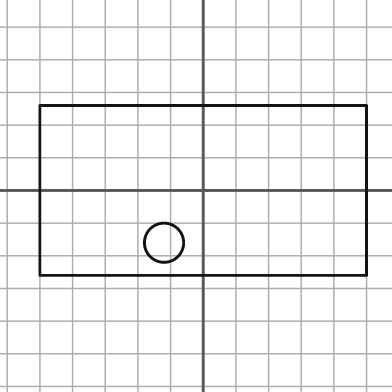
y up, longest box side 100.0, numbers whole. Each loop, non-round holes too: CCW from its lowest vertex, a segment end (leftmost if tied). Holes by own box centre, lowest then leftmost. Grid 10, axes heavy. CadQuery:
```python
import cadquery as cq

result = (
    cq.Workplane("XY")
    .moveTo(-50.0, -26.0)
    .lineTo(50.0, -26.0)
    .lineTo(50.0, 26.0)
    .lineTo(-50.0, 26.0)
    .close()
    .moveTo(-12.0, -16.0)
    .circle(6.0)
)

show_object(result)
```